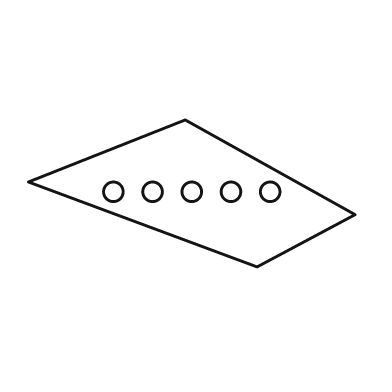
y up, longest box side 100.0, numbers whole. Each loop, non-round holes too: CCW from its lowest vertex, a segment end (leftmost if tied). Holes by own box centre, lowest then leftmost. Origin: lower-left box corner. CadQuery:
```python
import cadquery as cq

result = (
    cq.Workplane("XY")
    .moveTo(70.0, 0.0)
    .lineTo(100.0, 16.0)
    .lineTo(48.0, 45.0)
    .lineTo(0.0, 26.0)
    .close()
    .moveTo(26.0, 23.0)
    .circle(3.0)
    .moveTo(38.0, 23.0)
    .circle(3.0)
    .moveTo(50.0, 23.0)
    .circle(3.0)
    .moveTo(62.0, 23.0)
    .circle(3.0)
    .moveTo(74.0, 23.0)
    .circle(3.0)
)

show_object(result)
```